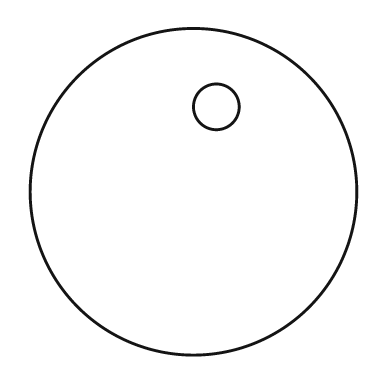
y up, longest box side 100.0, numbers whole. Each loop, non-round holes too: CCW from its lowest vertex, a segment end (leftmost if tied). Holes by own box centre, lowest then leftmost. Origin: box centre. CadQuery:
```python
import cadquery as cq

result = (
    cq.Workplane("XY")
    .moveTo(0.0, 0.0)
    .circle(50.0)
    .moveTo(7.0, 26.0)
    .circle(7.0)
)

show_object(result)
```